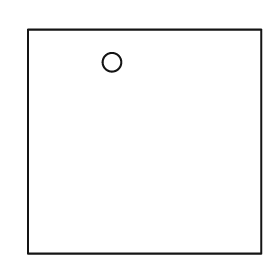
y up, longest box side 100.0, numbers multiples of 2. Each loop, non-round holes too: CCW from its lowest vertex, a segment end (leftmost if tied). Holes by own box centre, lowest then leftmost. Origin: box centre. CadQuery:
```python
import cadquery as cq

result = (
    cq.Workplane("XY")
    .moveTo(-50.0, -48.0)
    .lineTo(50.0, -48.0)
    .lineTo(50.0, 48.0)
    .lineTo(-50.0, 48.0)
    .close()
    .moveTo(-14.0, 34.0)
    .circle(4.0)
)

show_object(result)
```